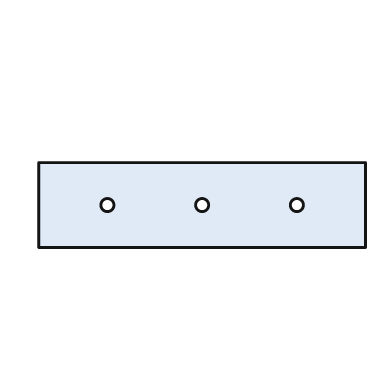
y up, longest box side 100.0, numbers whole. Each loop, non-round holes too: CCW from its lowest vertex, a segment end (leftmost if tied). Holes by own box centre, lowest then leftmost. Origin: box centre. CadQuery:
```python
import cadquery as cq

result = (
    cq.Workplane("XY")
    .moveTo(-50.0, -13.0)
    .lineTo(50.0, -13.0)
    .lineTo(50.0, 13.0)
    .lineTo(-50.0, 13.0)
    .close()
    .moveTo(-29.0, 0.0)
    .circle(2.0)
    .moveTo(0.0, 0.0)
    .circle(2.0)
    .moveTo(29.0, 0.0)
    .circle(2.0)
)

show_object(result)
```